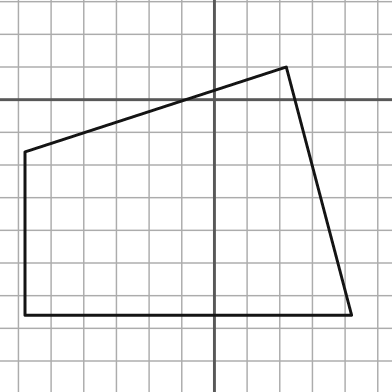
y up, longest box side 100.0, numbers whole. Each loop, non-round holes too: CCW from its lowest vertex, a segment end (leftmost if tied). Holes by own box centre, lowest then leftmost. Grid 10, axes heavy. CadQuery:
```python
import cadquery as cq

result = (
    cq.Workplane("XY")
    .moveTo(-58.0, -66.0)
    .lineTo(42.0, -66.0)
    .lineTo(22.0, 10.0)
    .lineTo(-58.0, -16.0)
    .close()
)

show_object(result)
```